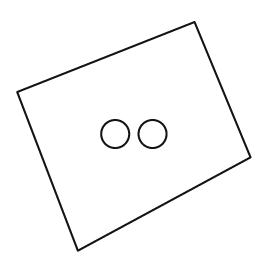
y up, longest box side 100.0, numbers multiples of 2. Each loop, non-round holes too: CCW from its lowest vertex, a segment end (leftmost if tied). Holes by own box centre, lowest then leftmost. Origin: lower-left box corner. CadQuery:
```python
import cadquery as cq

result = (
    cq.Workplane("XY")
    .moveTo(26.0, 0.0)
    .lineTo(100.0, 40.0)
    .lineTo(76.0, 98.0)
    .lineTo(0.0, 68.0)
    .close()
    .moveTo(42.0, 50.0)
    .circle(6.0)
    .moveTo(58.0, 50.0)
    .circle(6.0)
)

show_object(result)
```